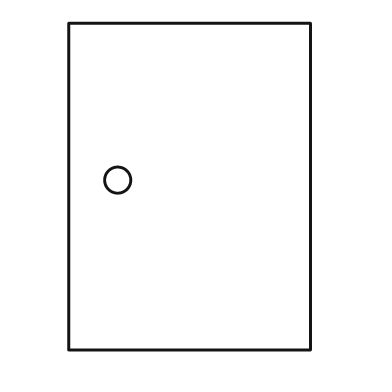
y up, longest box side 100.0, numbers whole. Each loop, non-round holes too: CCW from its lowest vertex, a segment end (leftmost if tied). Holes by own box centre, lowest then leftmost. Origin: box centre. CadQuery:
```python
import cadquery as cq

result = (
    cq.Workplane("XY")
    .moveTo(-37.0, -50.0)
    .lineTo(37.0, -50.0)
    .lineTo(37.0, 50.0)
    .lineTo(-37.0, 50.0)
    .close()
    .moveTo(-22.0, 2.0)
    .circle(4.0)
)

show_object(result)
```